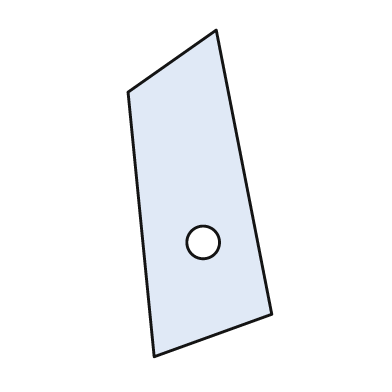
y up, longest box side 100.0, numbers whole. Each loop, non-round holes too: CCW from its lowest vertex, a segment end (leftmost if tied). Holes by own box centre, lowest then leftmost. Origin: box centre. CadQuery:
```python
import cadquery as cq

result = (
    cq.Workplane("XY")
    .moveTo(-14.0, -50.0)
    .lineTo(22.0, -37.0)
    .lineTo(5.0, 50.0)
    .lineTo(-22.0, 31.0)
    .close()
    .moveTo(1.0, -15.0)
    .circle(5.0)
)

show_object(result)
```